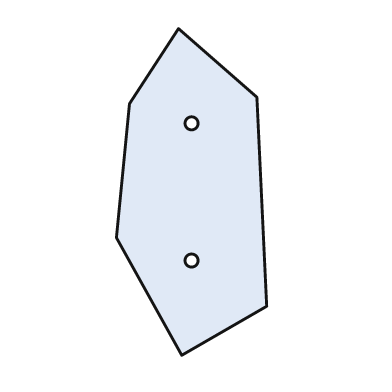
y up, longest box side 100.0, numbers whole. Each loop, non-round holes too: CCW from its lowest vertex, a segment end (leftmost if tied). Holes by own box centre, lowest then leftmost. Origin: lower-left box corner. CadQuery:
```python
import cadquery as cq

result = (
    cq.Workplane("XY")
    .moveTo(20.0, 0.0)
    .lineTo(46.0, 15.0)
    .lineTo(43.0, 79.0)
    .lineTo(19.0, 100.0)
    .lineTo(4.0, 77.0)
    .lineTo(0.0, 36.0)
    .close()
    .moveTo(23.0, 29.0)
    .circle(2.0)
    .moveTo(23.0, 71.0)
    .circle(2.0)
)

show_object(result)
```